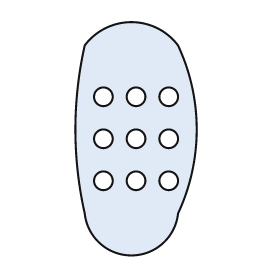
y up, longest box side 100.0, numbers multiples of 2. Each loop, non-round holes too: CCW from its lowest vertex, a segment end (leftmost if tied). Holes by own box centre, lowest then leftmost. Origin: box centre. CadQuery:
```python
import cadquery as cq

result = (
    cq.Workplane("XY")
    .moveTo(-22.0, -32.0)
    .threePointArc((-2.0, -50.0), (18.0, -32.0))
    .threePointArc((26.0, 4.0), (18.0, 40.0))
    .threePointArc((-2.0, 50.0), (-22.0, 40.0))
    .threePointArc((-26.0, 4.0), (-22.0, -32.0))
    .close()
    .moveTo(-14.0, -18.0)
    .circle(4.0)
    .moveTo(0.0, -18.0)
    .circle(4.0)
    .moveTo(14.0, -18.0)
    .circle(4.0)
    .moveTo(-14.0, 0.0)
    .circle(4.0)
    .moveTo(0.0, 0.0)
    .circle(4.0)
    .moveTo(14.0, 0.0)
    .circle(4.0)
    .moveTo(-14.0, 18.0)
    .circle(4.0)
    .moveTo(0.0, 18.0)
    .circle(4.0)
    .moveTo(14.0, 18.0)
    .circle(4.0)
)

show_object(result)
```